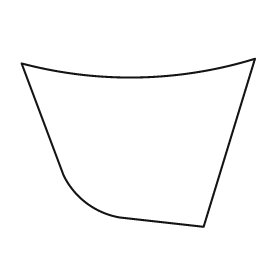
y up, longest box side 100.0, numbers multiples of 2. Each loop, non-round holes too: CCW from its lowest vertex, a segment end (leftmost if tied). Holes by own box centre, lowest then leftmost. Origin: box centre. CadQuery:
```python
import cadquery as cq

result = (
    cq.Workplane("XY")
    .moveTo(28.0, -36.0)
    .lineTo(50.0, 36.0)
    .threePointArc((0.0, 28.0), (-50.0, 34.0))
    .lineTo(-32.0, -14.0)
    .threePointArc((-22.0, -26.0), (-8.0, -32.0))
    .close()
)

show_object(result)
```